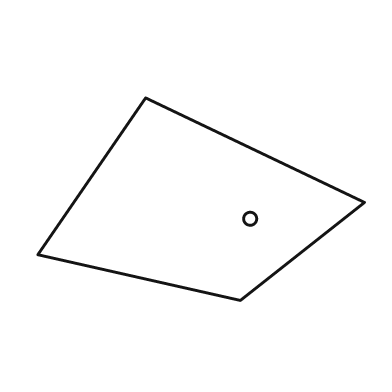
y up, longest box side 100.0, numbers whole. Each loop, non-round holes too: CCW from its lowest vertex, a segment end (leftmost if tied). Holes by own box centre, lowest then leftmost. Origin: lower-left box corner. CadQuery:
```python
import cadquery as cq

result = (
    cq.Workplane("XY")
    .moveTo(62.0, 0.0)
    .lineTo(100.0, 30.0)
    .lineTo(33.0, 62.0)
    .lineTo(0.0, 14.0)
    .close()
    .moveTo(65.0, 25.0)
    .circle(2.0)
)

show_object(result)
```